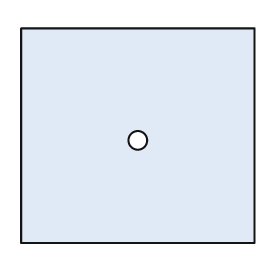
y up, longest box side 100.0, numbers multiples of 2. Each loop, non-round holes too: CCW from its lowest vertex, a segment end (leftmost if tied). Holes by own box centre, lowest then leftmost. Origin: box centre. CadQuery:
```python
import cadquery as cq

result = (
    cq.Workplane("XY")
    .moveTo(-50.0, -46.0)
    .lineTo(50.0, -46.0)
    .lineTo(50.0, 46.0)
    .lineTo(-50.0, 46.0)
    .close()
    .moveTo(0.0, -2.0)
    .circle(4.0)
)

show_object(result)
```